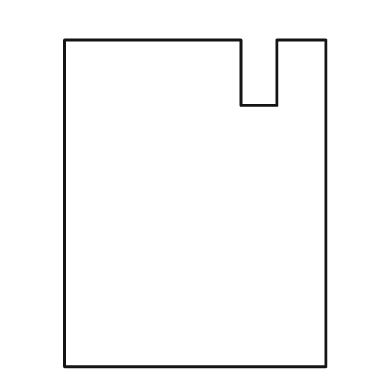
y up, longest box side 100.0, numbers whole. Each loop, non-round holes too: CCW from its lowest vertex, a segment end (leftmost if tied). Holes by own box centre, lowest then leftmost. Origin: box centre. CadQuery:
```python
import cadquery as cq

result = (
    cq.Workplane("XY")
    .moveTo(-40.0, -50.0)
    .lineTo(40.0, -50.0)
    .lineTo(40.0, 50.0)
    .lineTo(25.0, 50.0)
    .lineTo(25.0, 30.0)
    .lineTo(14.0, 30.0)
    .lineTo(14.0, 50.0)
    .lineTo(-40.0, 50.0)
    .close()
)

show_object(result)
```